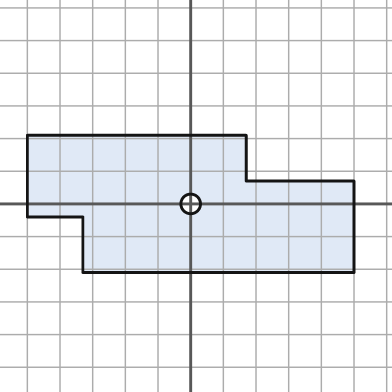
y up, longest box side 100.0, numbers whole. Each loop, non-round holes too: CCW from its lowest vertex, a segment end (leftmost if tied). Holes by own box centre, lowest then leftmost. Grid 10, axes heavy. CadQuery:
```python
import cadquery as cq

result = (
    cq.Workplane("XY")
    .moveTo(-33.0, -21.0)
    .lineTo(50.0, -21.0)
    .lineTo(50.0, 7.0)
    .lineTo(17.0, 7.0)
    .lineTo(17.0, 21.0)
    .lineTo(-50.0, 21.0)
    .lineTo(-50.0, -4.0)
    .lineTo(-33.0, -4.0)
    .close()
    .moveTo(0.0, 0.0)
    .circle(3.0)
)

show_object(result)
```